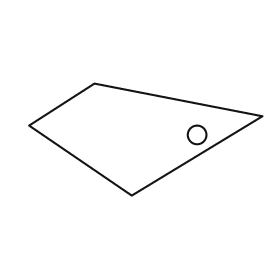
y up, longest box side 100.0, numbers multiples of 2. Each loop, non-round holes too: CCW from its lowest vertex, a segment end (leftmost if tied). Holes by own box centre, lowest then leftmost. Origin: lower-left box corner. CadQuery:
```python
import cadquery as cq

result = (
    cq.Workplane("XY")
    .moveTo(44.0, 0.0)
    .lineTo(100.0, 34.0)
    .lineTo(28.0, 48.0)
    .lineTo(0.0, 30.0)
    .close()
    .moveTo(72.0, 26.0)
    .circle(4.0)
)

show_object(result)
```